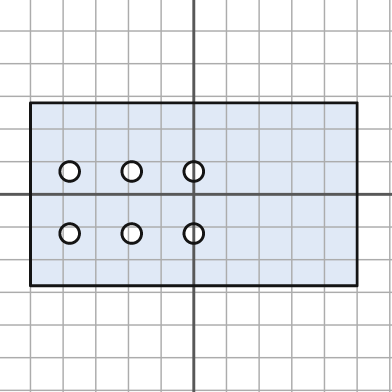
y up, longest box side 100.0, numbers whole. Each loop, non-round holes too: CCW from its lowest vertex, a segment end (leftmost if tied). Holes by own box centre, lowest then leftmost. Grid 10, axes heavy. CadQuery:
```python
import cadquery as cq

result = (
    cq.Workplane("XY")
    .moveTo(-50.0, -28.0)
    .lineTo(50.0, -28.0)
    .lineTo(50.0, 28.0)
    .lineTo(-50.0, 28.0)
    .close()
    .moveTo(-38.0, -12.0)
    .circle(3.0)
    .moveTo(-19.0, -12.0)
    .circle(3.0)
    .moveTo(0.0, -12.0)
    .circle(3.0)
    .moveTo(-38.0, 7.0)
    .circle(3.0)
    .moveTo(-19.0, 7.0)
    .circle(3.0)
    .moveTo(0.0, 7.0)
    .circle(3.0)
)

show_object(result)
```